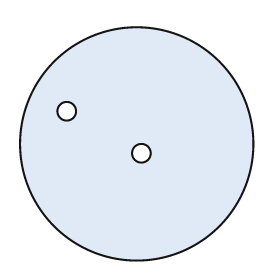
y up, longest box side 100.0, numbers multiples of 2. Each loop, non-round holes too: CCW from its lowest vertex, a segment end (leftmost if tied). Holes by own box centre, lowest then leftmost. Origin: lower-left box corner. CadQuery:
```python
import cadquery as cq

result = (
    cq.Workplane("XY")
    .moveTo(50.0, 50.0)
    .circle(50.0)
    .moveTo(52.0, 46.0)
    .circle(4.0)
    .moveTo(20.0, 64.0)
    .circle(4.0)
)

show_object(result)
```